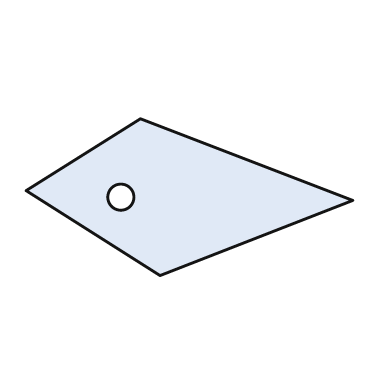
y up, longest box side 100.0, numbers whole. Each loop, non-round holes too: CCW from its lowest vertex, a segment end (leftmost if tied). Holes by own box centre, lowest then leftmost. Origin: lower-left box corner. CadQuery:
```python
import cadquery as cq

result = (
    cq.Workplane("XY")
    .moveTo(41.0, 0.0)
    .lineTo(100.0, 23.0)
    .lineTo(35.0, 48.0)
    .lineTo(0.0, 26.0)
    .close()
    .moveTo(29.0, 24.0)
    .circle(4.0)
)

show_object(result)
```